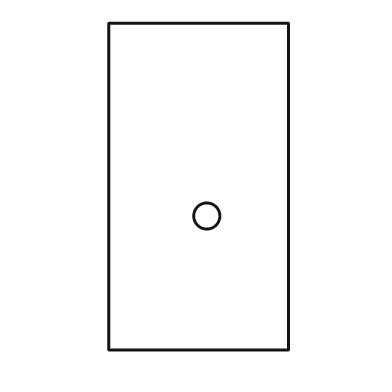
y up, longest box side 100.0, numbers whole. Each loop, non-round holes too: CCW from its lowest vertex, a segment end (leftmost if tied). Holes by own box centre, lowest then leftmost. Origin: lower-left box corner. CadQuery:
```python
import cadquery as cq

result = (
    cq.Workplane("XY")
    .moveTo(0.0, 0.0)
    .lineTo(55.0, 0.0)
    .lineTo(55.0, 100.0)
    .lineTo(0.0, 100.0)
    .close()
    .moveTo(30.0, 41.0)
    .circle(4.0)
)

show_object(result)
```